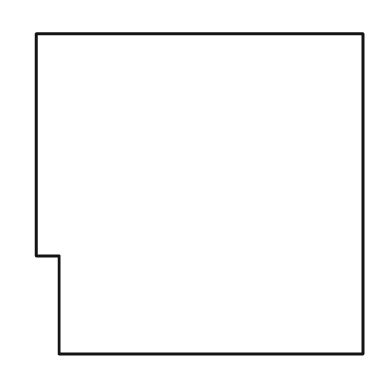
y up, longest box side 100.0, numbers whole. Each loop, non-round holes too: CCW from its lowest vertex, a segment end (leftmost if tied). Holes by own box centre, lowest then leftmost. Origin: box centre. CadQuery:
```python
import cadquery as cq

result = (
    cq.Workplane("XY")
    .moveTo(-43.0, -49.0)
    .lineTo(50.0, -49.0)
    .lineTo(50.0, 49.0)
    .lineTo(-50.0, 49.0)
    .lineTo(-50.0, -19.0)
    .lineTo(-43.0, -19.0)
    .close()
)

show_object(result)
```